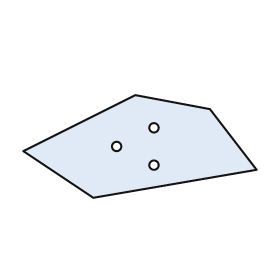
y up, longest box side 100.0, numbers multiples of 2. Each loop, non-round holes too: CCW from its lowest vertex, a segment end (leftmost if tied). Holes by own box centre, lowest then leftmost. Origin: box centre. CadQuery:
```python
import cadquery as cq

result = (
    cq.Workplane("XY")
    .moveTo(-20.0, -22.0)
    .lineTo(50.0, -10.0)
    .lineTo(30.0, 16.0)
    .lineTo(-2.0, 22.0)
    .lineTo(-50.0, -2.0)
    .close()
    .moveTo(6.0, -8.0)
    .circle(2.0)
    .moveTo(-10.0, 0.0)
    .circle(2.0)
    .moveTo(6.0, 8.0)
    .circle(2.0)
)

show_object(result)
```